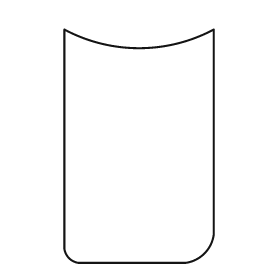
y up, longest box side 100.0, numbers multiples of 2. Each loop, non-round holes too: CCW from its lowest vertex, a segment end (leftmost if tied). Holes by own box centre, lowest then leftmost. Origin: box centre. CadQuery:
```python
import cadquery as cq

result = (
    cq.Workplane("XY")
    .moveTo(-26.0, -50.0)
    .lineTo(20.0, -50.0)
    .threePointArc((28.0, -46.0), (32.0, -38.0))
    .lineTo(32.0, 50.0)
    .threePointArc((0.0, 42.0), (-32.0, 50.0))
    .lineTo(-32.0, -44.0)
    .threePointArc((-30.0, -48.0), (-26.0, -50.0))
    .close()
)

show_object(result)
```